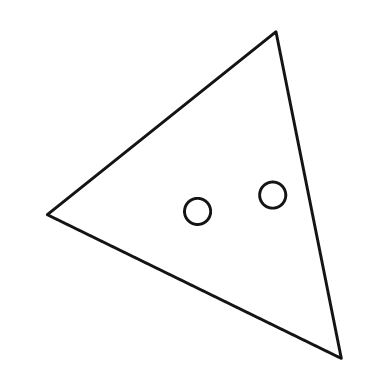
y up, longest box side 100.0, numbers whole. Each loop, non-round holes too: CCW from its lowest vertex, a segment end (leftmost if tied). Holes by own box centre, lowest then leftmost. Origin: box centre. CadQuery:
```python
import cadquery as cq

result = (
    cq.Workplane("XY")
    .moveTo(45.0, -50.0)
    .lineTo(25.0, 50.0)
    .lineTo(-45.0, -6.0)
    .close()
    .moveTo(1.0, -5.0)
    .circle(4.0)
    .moveTo(24.0, 0.0)
    .circle(4.0)
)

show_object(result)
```